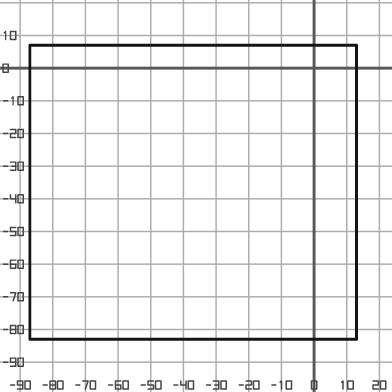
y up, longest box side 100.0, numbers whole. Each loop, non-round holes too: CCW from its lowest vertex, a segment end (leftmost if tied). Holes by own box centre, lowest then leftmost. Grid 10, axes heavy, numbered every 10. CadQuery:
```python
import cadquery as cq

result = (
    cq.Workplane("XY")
    .moveTo(-87.0, -83.0)
    .lineTo(13.0, -83.0)
    .lineTo(13.0, 7.0)
    .lineTo(-87.0, 7.0)
    .close()
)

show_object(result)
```